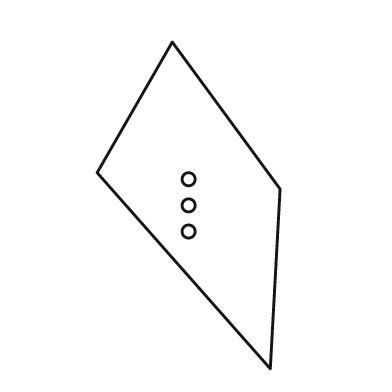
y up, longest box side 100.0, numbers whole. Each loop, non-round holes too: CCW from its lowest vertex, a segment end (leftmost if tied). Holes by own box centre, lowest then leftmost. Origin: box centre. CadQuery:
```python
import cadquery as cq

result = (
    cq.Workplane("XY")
    .moveTo(25.0, -50.0)
    .lineTo(28.0, 5.0)
    .lineTo(-5.0, 50.0)
    .lineTo(-28.0, 10.0)
    .close()
    .moveTo(0.0, -8.0)
    .circle(2.0)
    .moveTo(0.0, 0.0)
    .circle(2.0)
    .moveTo(0.0, 8.0)
    .circle(2.0)
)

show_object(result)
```